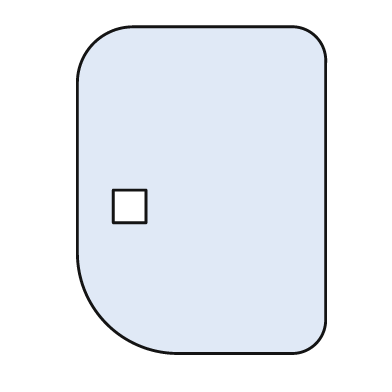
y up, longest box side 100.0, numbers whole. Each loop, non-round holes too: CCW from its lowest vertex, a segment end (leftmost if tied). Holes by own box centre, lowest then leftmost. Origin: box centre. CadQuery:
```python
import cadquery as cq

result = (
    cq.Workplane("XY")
    .moveTo(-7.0, -50.0)
    .lineTo(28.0, -50.0)
    .threePointArc((35.0, -47.0), (38.0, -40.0))
    .lineTo(38.0, 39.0)
    .threePointArc((35.0, 47.0), (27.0, 50.0))
    .lineTo(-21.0, 50.0)
    .threePointArc((-33.0, 45.0), (-38.0, 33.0))
    .lineTo(-38.0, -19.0)
    .threePointArc((-29.0, -41.0), (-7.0, -50.0))
    .close()
    .moveTo(-27.0, -10.0)
    .lineTo(-17.0, -10.0)
    .lineTo(-17.0, 0.0)
    .lineTo(-27.0, 0.0)
    .close()
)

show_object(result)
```